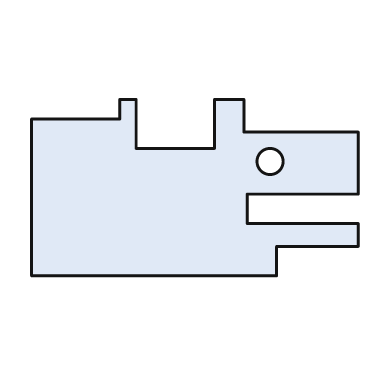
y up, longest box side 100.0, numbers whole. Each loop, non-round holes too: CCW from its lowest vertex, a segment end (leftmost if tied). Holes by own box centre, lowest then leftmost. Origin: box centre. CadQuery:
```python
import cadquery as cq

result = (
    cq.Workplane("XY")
    .moveTo(-50.0, -27.0)
    .lineTo(25.0, -27.0)
    .lineTo(25.0, -18.0)
    .lineTo(50.0, -18.0)
    .lineTo(50.0, -11.0)
    .lineTo(16.0, -11.0)
    .lineTo(16.0, -2.0)
    .lineTo(50.0, -2.0)
    .lineTo(50.0, 17.0)
    .lineTo(15.0, 17.0)
    .lineTo(15.0, 27.0)
    .lineTo(6.0, 27.0)
    .lineTo(6.0, 12.0)
    .lineTo(-18.0, 12.0)
    .lineTo(-18.0, 27.0)
    .lineTo(-23.0, 27.0)
    .lineTo(-23.0, 21.0)
    .lineTo(-50.0, 21.0)
    .close()
    .moveTo(23.0, 8.0)
    .circle(4.0)
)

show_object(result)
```